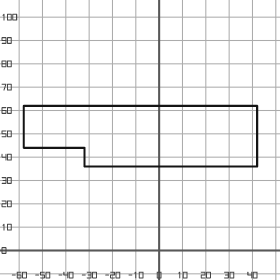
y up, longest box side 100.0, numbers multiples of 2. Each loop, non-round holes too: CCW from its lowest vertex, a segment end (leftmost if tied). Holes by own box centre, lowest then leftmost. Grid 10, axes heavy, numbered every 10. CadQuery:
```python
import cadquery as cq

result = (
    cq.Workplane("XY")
    .moveTo(-32.0, 36.0)
    .lineTo(42.0, 36.0)
    .lineTo(42.0, 62.0)
    .lineTo(-58.0, 62.0)
    .lineTo(-58.0, 44.0)
    .lineTo(-32.0, 44.0)
    .close()
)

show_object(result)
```